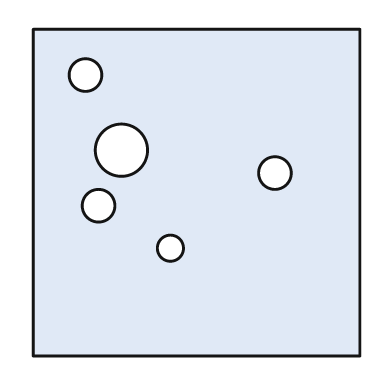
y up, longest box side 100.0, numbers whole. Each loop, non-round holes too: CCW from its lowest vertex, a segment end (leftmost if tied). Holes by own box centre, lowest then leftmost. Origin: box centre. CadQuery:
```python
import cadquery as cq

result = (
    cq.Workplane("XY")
    .moveTo(-50.0, -50.0)
    .lineTo(50.0, -50.0)
    .lineTo(50.0, 50.0)
    .lineTo(-50.0, 50.0)
    .close()
    .moveTo(-8.0, -17.0)
    .circle(4.0)
    .moveTo(-30.0, -4.0)
    .circle(5.0)
    .moveTo(24.0, 6.0)
    .circle(5.0)
    .moveTo(-23.0, 13.0)
    .circle(8.0)
    .moveTo(-34.0, 36.0)
    .circle(5.0)
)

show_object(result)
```